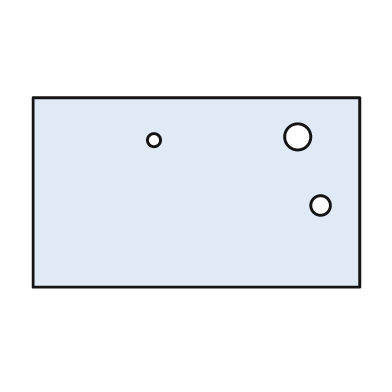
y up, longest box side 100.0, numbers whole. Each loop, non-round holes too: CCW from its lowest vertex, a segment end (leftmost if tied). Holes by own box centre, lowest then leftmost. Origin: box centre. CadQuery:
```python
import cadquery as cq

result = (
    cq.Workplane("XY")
    .moveTo(-50.0, -29.0)
    .lineTo(50.0, -29.0)
    .lineTo(50.0, 29.0)
    .lineTo(-50.0, 29.0)
    .close()
    .moveTo(38.0, -4.0)
    .circle(3.0)
    .moveTo(-13.0, 16.0)
    .circle(2.0)
    .moveTo(31.0, 17.0)
    .circle(4.0)
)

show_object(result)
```